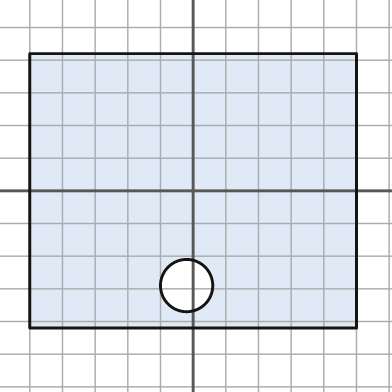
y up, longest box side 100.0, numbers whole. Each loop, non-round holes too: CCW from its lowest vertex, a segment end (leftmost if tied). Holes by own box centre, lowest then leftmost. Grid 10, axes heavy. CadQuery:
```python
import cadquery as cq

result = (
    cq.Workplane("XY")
    .moveTo(-50.0, -42.0)
    .lineTo(50.0, -42.0)
    .lineTo(50.0, 42.0)
    .lineTo(-50.0, 42.0)
    .close()
    .moveTo(-2.0, -29.0)
    .circle(8.0)
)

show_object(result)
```